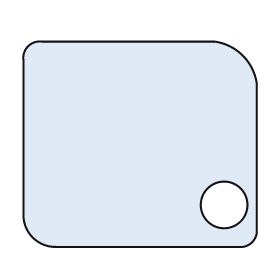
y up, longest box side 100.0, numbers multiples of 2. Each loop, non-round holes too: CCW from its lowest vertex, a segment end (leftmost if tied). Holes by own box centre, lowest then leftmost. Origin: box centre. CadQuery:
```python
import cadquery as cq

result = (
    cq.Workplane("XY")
    .moveTo(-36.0, -44.0)
    .lineTo(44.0, -44.0)
    .threePointArc((48.0, -42.0), (50.0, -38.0))
    .lineTo(50.0, 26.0)
    .threePointArc((44.0, 38.0), (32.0, 44.0))
    .lineTo(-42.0, 44.0)
    .threePointArc((-48.0, 42.0), (-50.0, 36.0))
    .lineTo(-50.0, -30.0)
    .threePointArc((-46.0, -40.0), (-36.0, -44.0))
    .close()
    .moveTo(36.0, -26.0)
    .circle(10.0)
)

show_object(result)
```